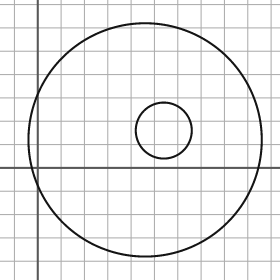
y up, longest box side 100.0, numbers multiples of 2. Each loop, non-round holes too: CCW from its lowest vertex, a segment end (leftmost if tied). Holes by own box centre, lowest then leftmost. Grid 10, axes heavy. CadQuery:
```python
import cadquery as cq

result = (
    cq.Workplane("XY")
    .moveTo(46.0, 12.0)
    .circle(50.0)
    .moveTo(54.0, 16.0)
    .circle(12.0)
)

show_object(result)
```